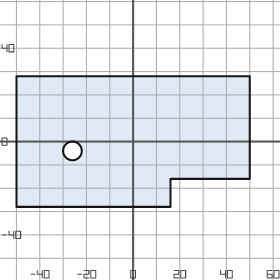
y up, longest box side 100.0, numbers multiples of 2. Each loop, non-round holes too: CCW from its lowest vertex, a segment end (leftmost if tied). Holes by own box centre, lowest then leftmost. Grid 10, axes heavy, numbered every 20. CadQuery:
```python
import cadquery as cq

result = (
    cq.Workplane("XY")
    .moveTo(-50.0, -28.0)
    .lineTo(16.0, -28.0)
    .lineTo(16.0, -16.0)
    .lineTo(50.0, -16.0)
    .lineTo(50.0, 28.0)
    .lineTo(-50.0, 28.0)
    .close()
    .moveTo(-26.0, -4.0)
    .circle(4.0)
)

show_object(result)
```